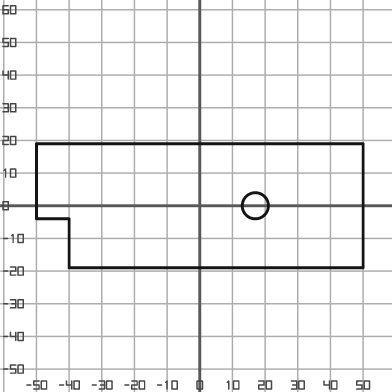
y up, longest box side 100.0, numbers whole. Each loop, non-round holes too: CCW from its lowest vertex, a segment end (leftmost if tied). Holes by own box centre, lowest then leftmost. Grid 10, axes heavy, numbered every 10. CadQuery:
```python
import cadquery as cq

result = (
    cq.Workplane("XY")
    .moveTo(-40.0, -19.0)
    .lineTo(50.0, -19.0)
    .lineTo(50.0, 19.0)
    .lineTo(-50.0, 19.0)
    .lineTo(-50.0, -4.0)
    .lineTo(-40.0, -4.0)
    .close()
    .moveTo(17.0, 0.0)
    .circle(4.0)
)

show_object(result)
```